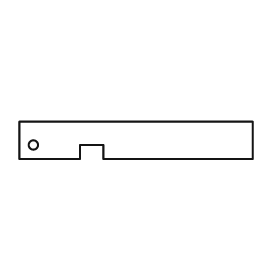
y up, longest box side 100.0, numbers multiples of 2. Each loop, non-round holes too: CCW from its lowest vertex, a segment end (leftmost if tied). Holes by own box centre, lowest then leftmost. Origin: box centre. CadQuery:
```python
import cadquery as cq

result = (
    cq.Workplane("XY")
    .moveTo(-50.0, -8.0)
    .lineTo(-24.0, -8.0)
    .lineTo(-24.0, -2.0)
    .lineTo(-14.0, -2.0)
    .lineTo(-14.0, -8.0)
    .lineTo(50.0, -8.0)
    .lineTo(50.0, 8.0)
    .lineTo(-50.0, 8.0)
    .close()
    .moveTo(-44.0, -2.0)
    .circle(2.0)
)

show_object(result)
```